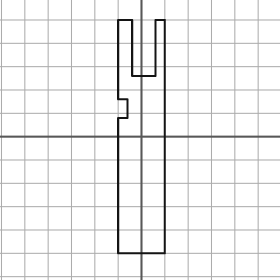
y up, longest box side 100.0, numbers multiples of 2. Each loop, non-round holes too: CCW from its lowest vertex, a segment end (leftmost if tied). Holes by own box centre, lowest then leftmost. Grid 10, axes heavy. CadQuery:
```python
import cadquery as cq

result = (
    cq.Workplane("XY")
    .moveTo(-10.0, -50.0)
    .lineTo(10.0, -50.0)
    .lineTo(10.0, 50.0)
    .lineTo(6.0, 50.0)
    .lineTo(6.0, 26.0)
    .lineTo(-4.0, 26.0)
    .lineTo(-4.0, 50.0)
    .lineTo(-10.0, 50.0)
    .lineTo(-10.0, 16.0)
    .lineTo(-6.0, 16.0)
    .lineTo(-6.0, 8.0)
    .lineTo(-10.0, 8.0)
    .close()
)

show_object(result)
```